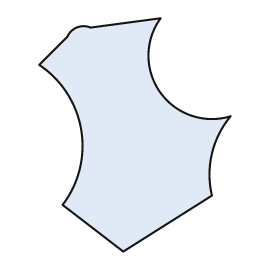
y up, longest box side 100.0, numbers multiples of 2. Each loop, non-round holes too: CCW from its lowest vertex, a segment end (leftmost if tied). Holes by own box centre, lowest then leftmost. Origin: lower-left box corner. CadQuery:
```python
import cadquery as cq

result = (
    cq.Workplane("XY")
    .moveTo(36.0, 0.0)
    .lineTo(74.0, 24.0)
    .threePointArc((74.0, 42.0), (82.0, 58.0))
    .threePointArc((52.0, 68.0), (52.0, 100.0))
    .lineTo(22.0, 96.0)
    .threePointArc((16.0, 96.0), (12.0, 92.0))
    .lineTo(0.0, 80.0)
    .threePointArc((18.0, 52.0), (10.0, 20.0))
    .close()
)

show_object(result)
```